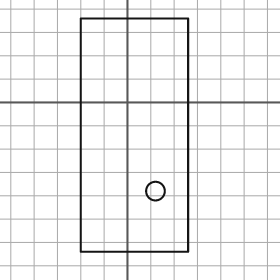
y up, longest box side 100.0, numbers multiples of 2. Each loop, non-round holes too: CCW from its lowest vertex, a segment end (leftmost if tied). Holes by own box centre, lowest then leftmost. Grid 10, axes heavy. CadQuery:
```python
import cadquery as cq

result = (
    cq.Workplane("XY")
    .moveTo(-20.0, -64.0)
    .lineTo(26.0, -64.0)
    .lineTo(26.0, 36.0)
    .lineTo(-20.0, 36.0)
    .close()
    .moveTo(12.0, -38.0)
    .circle(4.0)
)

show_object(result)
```